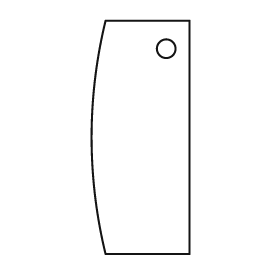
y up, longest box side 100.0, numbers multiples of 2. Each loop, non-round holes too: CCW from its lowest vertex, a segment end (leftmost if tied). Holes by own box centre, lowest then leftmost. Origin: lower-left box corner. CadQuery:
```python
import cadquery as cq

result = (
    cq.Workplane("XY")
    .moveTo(6.0, 0.0)
    .lineTo(42.0, 0.0)
    .lineTo(42.0, 100.0)
    .lineTo(6.0, 100.0)
    .threePointArc((0.0, 50.0), (6.0, 0.0))
    .close()
    .moveTo(32.0, 88.0)
    .circle(4.0)
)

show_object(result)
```